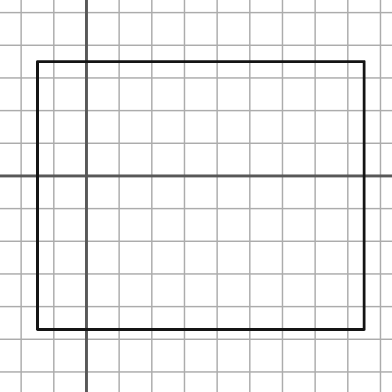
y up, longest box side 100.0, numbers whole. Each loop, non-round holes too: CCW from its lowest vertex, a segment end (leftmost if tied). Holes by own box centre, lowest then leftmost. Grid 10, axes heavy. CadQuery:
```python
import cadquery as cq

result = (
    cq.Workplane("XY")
    .moveTo(-15.0, -47.0)
    .lineTo(85.0, -47.0)
    .lineTo(85.0, 35.0)
    .lineTo(-15.0, 35.0)
    .close()
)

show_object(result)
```